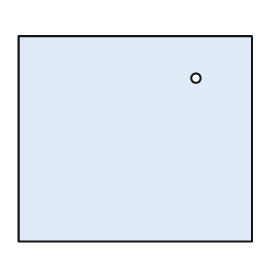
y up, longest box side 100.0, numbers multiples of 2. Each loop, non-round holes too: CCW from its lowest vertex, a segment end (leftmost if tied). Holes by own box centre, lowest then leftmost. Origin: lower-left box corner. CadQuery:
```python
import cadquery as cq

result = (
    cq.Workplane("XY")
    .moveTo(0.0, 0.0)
    .lineTo(100.0, 0.0)
    .lineTo(100.0, 88.0)
    .lineTo(0.0, 88.0)
    .close()
    .moveTo(76.0, 70.0)
    .circle(2.0)
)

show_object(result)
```